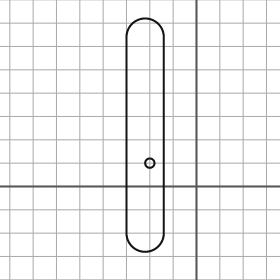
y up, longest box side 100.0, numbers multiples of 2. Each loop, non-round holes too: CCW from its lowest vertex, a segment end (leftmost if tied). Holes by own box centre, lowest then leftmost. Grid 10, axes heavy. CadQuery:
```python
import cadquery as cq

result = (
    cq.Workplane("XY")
    .moveTo(-30.0, -20.0)
    .threePointArc((-22.0, -28.0), (-14.0, -20.0))
    .lineTo(-14.0, 64.0)
    .threePointArc((-22.0, 72.0), (-30.0, 64.0))
    .close()
    .moveTo(-20.0, 10.0)
    .circle(2.0)
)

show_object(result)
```